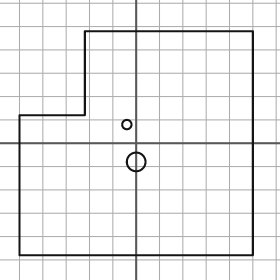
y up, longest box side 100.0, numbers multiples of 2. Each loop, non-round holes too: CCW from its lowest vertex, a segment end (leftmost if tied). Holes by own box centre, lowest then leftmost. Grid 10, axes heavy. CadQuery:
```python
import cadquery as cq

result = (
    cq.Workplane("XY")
    .moveTo(-50.0, -48.0)
    .lineTo(50.0, -48.0)
    .lineTo(50.0, 48.0)
    .lineTo(-22.0, 48.0)
    .lineTo(-22.0, 12.0)
    .lineTo(-50.0, 12.0)
    .close()
    .moveTo(0.0, -8.0)
    .circle(4.0)
    .moveTo(-4.0, 8.0)
    .circle(2.0)
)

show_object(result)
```